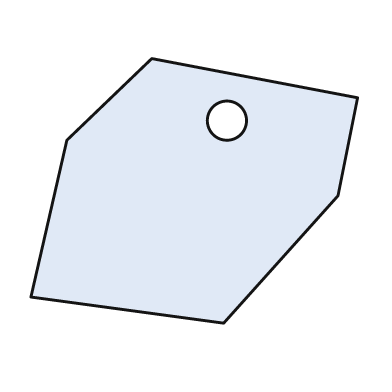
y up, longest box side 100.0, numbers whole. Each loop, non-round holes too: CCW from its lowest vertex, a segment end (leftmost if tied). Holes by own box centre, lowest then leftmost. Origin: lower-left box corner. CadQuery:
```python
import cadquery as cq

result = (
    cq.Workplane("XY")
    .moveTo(59.0, 0.0)
    .lineTo(94.0, 39.0)
    .lineTo(100.0, 69.0)
    .lineTo(37.0, 81.0)
    .lineTo(11.0, 56.0)
    .lineTo(0.0, 8.0)
    .close()
    .moveTo(60.0, 62.0)
    .circle(6.0)
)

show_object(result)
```